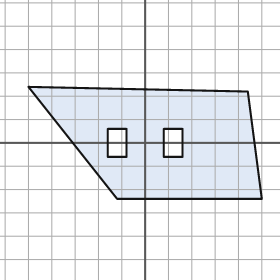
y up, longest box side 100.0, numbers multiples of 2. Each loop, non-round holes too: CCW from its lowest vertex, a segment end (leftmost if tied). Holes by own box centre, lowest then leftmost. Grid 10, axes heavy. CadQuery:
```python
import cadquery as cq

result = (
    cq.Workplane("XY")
    .moveTo(-12.0, -24.0)
    .lineTo(50.0, -24.0)
    .lineTo(44.0, 22.0)
    .lineTo(-50.0, 24.0)
    .close()
    .moveTo(-16.0, -6.0)
    .lineTo(-8.0, -6.0)
    .lineTo(-8.0, 6.0)
    .lineTo(-16.0, 6.0)
    .close()
    .moveTo(8.0, -6.0)
    .lineTo(16.0, -6.0)
    .lineTo(16.0, 6.0)
    .lineTo(8.0, 6.0)
    .close()
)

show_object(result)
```